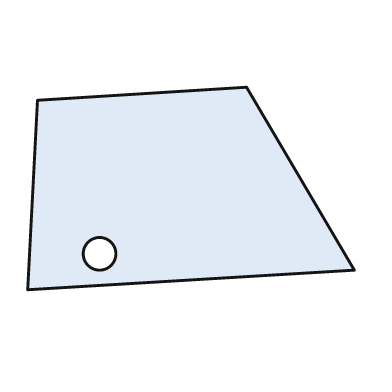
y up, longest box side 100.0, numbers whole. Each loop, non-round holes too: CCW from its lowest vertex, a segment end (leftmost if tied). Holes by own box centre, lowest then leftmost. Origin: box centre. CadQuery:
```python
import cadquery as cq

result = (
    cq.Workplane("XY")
    .moveTo(-50.0, -31.0)
    .lineTo(50.0, -25.0)
    .lineTo(17.0, 31.0)
    .lineTo(-47.0, 27.0)
    .close()
    .moveTo(-28.0, -20.0)
    .circle(5.0)
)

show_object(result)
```